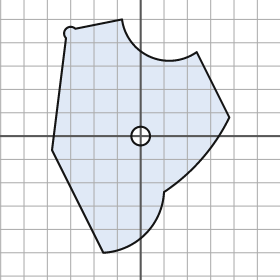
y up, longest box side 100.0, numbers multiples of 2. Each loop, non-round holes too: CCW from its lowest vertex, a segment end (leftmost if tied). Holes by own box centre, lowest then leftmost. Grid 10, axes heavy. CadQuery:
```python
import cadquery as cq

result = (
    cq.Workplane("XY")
    .moveTo(-16.0, -50.0)
    .threePointArc((2.0, -42.0), (10.0, -24.0))
    .threePointArc((26.0, -10.0), (38.0, 8.0))
    .lineTo(24.0, 36.0)
    .threePointArc((4.0, 34.0), (-8.0, 50.0))
    .lineTo(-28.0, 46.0)
    .threePointArc((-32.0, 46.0), (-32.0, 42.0))
    .lineTo(-38.0, -6.0)
    .close()
    .moveTo(0.0, 0.0)
    .circle(4.0)
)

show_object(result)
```